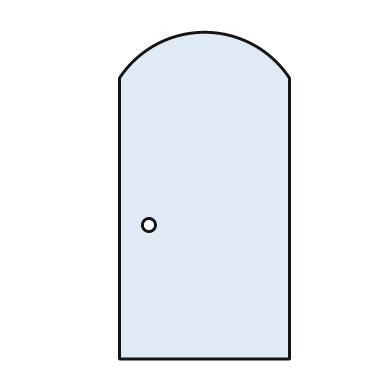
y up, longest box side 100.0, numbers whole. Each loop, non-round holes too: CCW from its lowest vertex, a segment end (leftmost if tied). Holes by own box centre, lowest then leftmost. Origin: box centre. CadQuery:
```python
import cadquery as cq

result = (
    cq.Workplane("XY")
    .moveTo(-26.0, -50.0)
    .lineTo(26.0, -50.0)
    .lineTo(26.0, 36.0)
    .threePointArc((0.0, 50.0), (-26.0, 36.0))
    .close()
    .moveTo(-17.0, -9.0)
    .circle(2.0)
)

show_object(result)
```